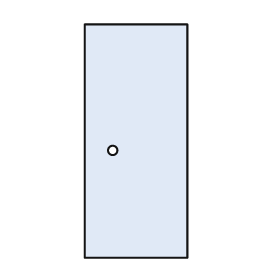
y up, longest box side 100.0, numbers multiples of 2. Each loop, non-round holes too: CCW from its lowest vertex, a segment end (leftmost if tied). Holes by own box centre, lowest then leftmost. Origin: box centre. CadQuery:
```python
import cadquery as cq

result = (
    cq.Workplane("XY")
    .moveTo(-22.0, -50.0)
    .lineTo(22.0, -50.0)
    .lineTo(22.0, 50.0)
    .lineTo(-22.0, 50.0)
    .close()
    .moveTo(-10.0, -4.0)
    .circle(2.0)
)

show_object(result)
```